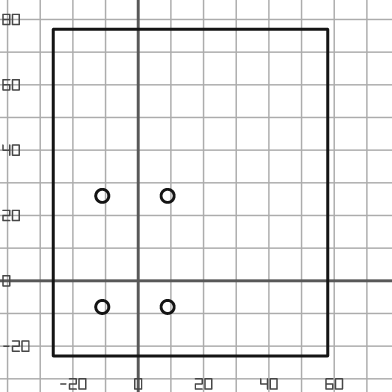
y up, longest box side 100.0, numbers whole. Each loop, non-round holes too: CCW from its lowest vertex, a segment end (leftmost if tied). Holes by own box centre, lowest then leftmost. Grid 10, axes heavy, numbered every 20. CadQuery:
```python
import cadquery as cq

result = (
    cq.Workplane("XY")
    .moveTo(-26.0, -23.0)
    .lineTo(58.0, -23.0)
    .lineTo(58.0, 77.0)
    .lineTo(-26.0, 77.0)
    .close()
    .moveTo(-11.0, -8.0)
    .circle(2.0)
    .moveTo(9.0, -8.0)
    .circle(2.0)
    .moveTo(-11.0, 26.0)
    .circle(2.0)
    .moveTo(9.0, 26.0)
    .circle(2.0)
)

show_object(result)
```